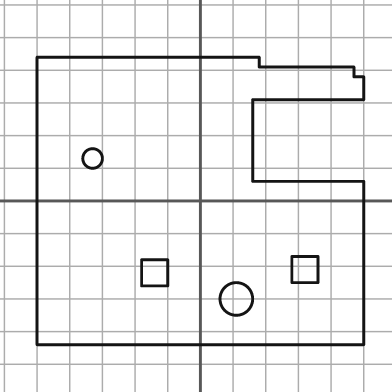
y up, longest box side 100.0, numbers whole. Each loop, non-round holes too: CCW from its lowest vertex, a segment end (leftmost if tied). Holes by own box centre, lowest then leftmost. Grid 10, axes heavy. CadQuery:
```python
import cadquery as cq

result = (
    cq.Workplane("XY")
    .moveTo(-50.0, -44.0)
    .lineTo(50.0, -44.0)
    .lineTo(50.0, 6.0)
    .lineTo(16.0, 6.0)
    .lineTo(16.0, 31.0)
    .lineTo(50.0, 31.0)
    .lineTo(50.0, 38.0)
    .lineTo(47.0, 38.0)
    .lineTo(47.0, 41.0)
    .lineTo(18.0, 41.0)
    .lineTo(18.0, 44.0)
    .lineTo(-50.0, 44.0)
    .close()
    .moveTo(11.0, -30.0)
    .circle(5.0)
    .moveTo(-18.0, -26.0)
    .lineTo(-10.0, -26.0)
    .lineTo(-10.0, -18.0)
    .lineTo(-18.0, -18.0)
    .close()
    .moveTo(28.0, -25.0)
    .lineTo(36.0, -25.0)
    .lineTo(36.0, -17.0)
    .lineTo(28.0, -17.0)
    .close()
    .moveTo(-33.0, 13.0)
    .circle(3.0)
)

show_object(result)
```